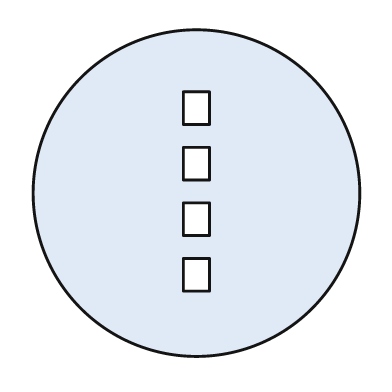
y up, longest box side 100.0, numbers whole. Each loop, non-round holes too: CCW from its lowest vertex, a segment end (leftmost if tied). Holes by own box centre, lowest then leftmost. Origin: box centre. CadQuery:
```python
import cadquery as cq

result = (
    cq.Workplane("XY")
    .moveTo(0.0, 0.0)
    .circle(50.0)
    .moveTo(-4.0, -30.0)
    .lineTo(4.0, -30.0)
    .lineTo(4.0, -20.0)
    .lineTo(-4.0, -20.0)
    .close()
    .moveTo(-4.0, -13.0)
    .lineTo(4.0, -13.0)
    .lineTo(4.0, -3.0)
    .lineTo(-4.0, -3.0)
    .close()
    .moveTo(-4.0, 4.0)
    .lineTo(4.0, 4.0)
    .lineTo(4.0, 14.0)
    .lineTo(-4.0, 14.0)
    .close()
    .moveTo(-4.0, 21.0)
    .lineTo(4.0, 21.0)
    .lineTo(4.0, 31.0)
    .lineTo(-4.0, 31.0)
    .close()
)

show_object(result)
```